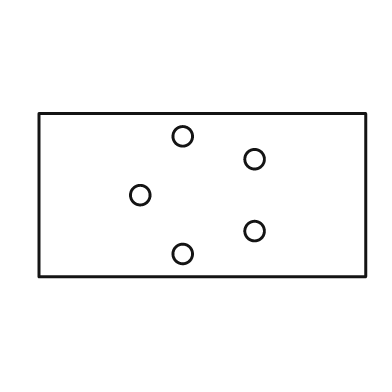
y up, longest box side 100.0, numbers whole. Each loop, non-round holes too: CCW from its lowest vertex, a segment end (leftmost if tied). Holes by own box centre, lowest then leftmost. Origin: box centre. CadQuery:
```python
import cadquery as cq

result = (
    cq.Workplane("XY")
    .moveTo(-50.0, -25.0)
    .lineTo(50.0, -25.0)
    .lineTo(50.0, 25.0)
    .lineTo(-50.0, 25.0)
    .close()
    .moveTo(-6.0, -18.0)
    .circle(3.0)
    .moveTo(16.0, -11.0)
    .circle(3.0)
    .moveTo(-19.0, 0.0)
    .circle(3.0)
    .moveTo(16.0, 11.0)
    .circle(3.0)
    .moveTo(-6.0, 18.0)
    .circle(3.0)
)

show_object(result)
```